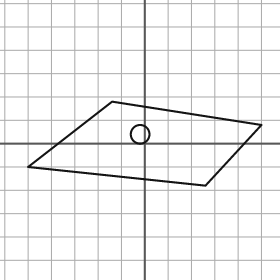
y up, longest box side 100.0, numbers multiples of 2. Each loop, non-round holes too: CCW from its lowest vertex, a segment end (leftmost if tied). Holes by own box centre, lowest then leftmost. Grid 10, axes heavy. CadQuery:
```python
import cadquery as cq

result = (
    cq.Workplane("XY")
    .moveTo(26.0, -18.0)
    .lineTo(50.0, 8.0)
    .lineTo(-14.0, 18.0)
    .lineTo(-50.0, -10.0)
    .close()
    .moveTo(-2.0, 4.0)
    .circle(4.0)
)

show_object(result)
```